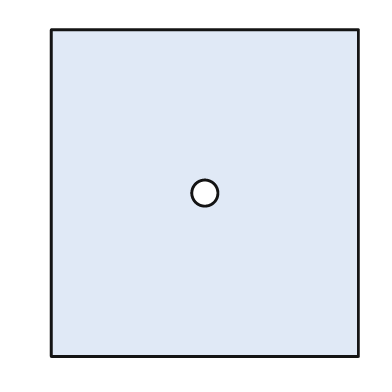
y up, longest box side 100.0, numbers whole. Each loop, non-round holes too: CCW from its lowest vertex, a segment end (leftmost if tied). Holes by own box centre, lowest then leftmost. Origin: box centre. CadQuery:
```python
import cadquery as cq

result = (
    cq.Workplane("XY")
    .moveTo(-47.0, -50.0)
    .lineTo(47.0, -50.0)
    .lineTo(47.0, 50.0)
    .lineTo(-47.0, 50.0)
    .close()
    .moveTo(0.0, 0.0)
    .circle(4.0)
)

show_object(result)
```